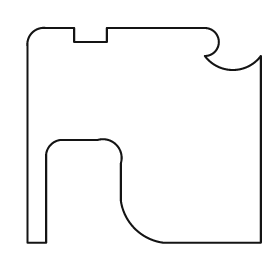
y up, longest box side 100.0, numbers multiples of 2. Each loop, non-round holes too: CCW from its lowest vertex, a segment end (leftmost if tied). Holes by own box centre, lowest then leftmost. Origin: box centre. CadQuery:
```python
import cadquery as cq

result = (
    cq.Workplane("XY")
    .moveTo(-50.0, -46.0)
    .lineTo(-42.0, -46.0)
    .lineTo(-42.0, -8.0)
    .threePointArc((-40.0, -4.0), (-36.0, -2.0))
    .lineTo(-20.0, -2.0)
    .threePointArc((-12.0, -4.0), (-10.0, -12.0))
    .lineTo(-10.0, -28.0)
    .threePointArc((-4.0, -40.0), (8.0, -46.0))
    .lineTo(50.0, -46.0)
    .lineTo(50.0, 34.0)
    .threePointArc((38.0, 28.0), (26.0, 34.0))
    .threePointArc((32.0, 40.0), (26.0, 46.0))
    .lineTo(-16.0, 46.0)
    .lineTo(-16.0, 40.0)
    .lineTo(-30.0, 40.0)
    .lineTo(-30.0, 46.0)
    .lineTo(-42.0, 46.0)
    .threePointArc((-48.0, 44.0), (-50.0, 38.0))
    .close()
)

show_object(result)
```